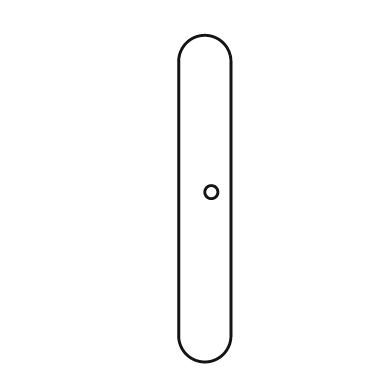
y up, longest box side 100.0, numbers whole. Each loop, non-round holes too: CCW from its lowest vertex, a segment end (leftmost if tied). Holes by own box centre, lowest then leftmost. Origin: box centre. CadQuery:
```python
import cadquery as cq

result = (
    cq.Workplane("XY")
    .moveTo(-8.0, -42.0)
    .threePointArc((0.0, -50.0), (8.0, -42.0))
    .lineTo(8.0, 42.0)
    .threePointArc((0.0, 50.0), (-8.0, 42.0))
    .close()
    .moveTo(2.0, 2.0)
    .circle(2.0)
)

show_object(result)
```